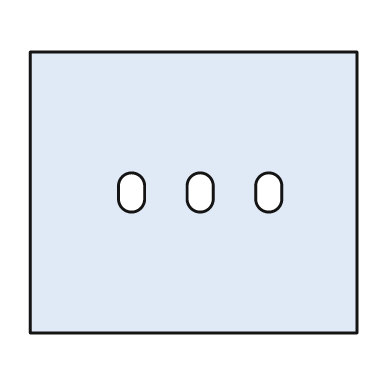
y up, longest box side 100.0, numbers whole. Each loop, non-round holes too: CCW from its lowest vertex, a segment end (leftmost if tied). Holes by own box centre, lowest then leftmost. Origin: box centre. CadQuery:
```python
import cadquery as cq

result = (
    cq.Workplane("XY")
    .moveTo(-50.0, -43.0)
    .lineTo(50.0, -43.0)
    .lineTo(50.0, 43.0)
    .lineTo(-50.0, 43.0)
    .close()
    .moveTo(-23.0, -2.0)
    .threePointArc((-19.0, -6.0), (-15.0, -2.0))
    .lineTo(-15.0, 2.0)
    .threePointArc((-19.0, 6.0), (-23.0, 2.0))
    .close()
    .moveTo(-2.0, -2.0)
    .threePointArc((2.0, -6.0), (6.0, -2.0))
    .lineTo(6.0, 2.0)
    .threePointArc((2.0, 6.0), (-2.0, 2.0))
    .close()
    .moveTo(19.0, -2.0)
    .threePointArc((23.0, -6.0), (27.0, -2.0))
    .lineTo(27.0, 2.0)
    .threePointArc((23.0, 6.0), (19.0, 2.0))
    .close()
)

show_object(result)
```